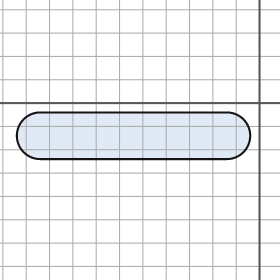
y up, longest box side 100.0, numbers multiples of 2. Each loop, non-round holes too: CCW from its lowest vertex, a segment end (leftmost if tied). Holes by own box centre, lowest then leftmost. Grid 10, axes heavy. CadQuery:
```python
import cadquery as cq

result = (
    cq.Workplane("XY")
    .moveTo(-94.0, -24.0)
    .lineTo(-14.0, -24.0)
    .threePointArc((-4.0, -14.0), (-14.0, -4.0))
    .lineTo(-94.0, -4.0)
    .threePointArc((-104.0, -14.0), (-94.0, -24.0))
    .close()
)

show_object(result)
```